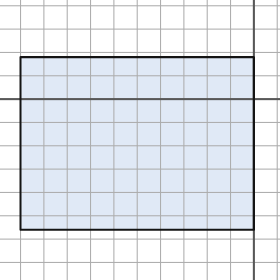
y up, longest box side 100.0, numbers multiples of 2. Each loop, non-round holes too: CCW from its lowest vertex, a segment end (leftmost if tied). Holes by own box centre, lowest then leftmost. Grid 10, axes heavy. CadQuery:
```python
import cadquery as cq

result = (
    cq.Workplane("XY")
    .moveTo(-100.0, -56.0)
    .lineTo(0.0, -56.0)
    .lineTo(0.0, 18.0)
    .lineTo(-100.0, 18.0)
    .close()
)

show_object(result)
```